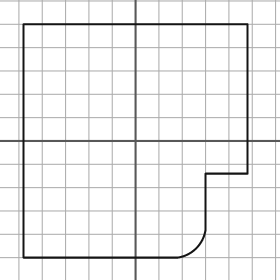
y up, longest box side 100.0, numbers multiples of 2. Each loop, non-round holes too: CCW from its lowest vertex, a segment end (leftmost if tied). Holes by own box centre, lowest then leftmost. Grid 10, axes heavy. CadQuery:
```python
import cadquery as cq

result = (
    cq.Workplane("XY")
    .moveTo(-48.0, -50.0)
    .lineTo(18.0, -50.0)
    .threePointArc((26.0, -46.0), (30.0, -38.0))
    .lineTo(30.0, -14.0)
    .lineTo(48.0, -14.0)
    .lineTo(48.0, 50.0)
    .lineTo(-48.0, 50.0)
    .close()
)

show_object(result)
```